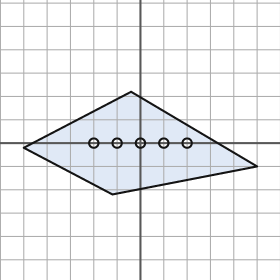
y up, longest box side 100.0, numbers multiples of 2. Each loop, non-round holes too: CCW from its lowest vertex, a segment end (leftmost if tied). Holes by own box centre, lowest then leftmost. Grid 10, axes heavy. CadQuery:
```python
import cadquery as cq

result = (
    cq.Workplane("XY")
    .moveTo(-12.0, -22.0)
    .lineTo(50.0, -10.0)
    .lineTo(-4.0, 22.0)
    .lineTo(-50.0, -2.0)
    .close()
    .moveTo(-20.0, 0.0)
    .circle(2.0)
    .moveTo(-10.0, 0.0)
    .circle(2.0)
    .moveTo(0.0, 0.0)
    .circle(2.0)
    .moveTo(10.0, 0.0)
    .circle(2.0)
    .moveTo(20.0, 0.0)
    .circle(2.0)
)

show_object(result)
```